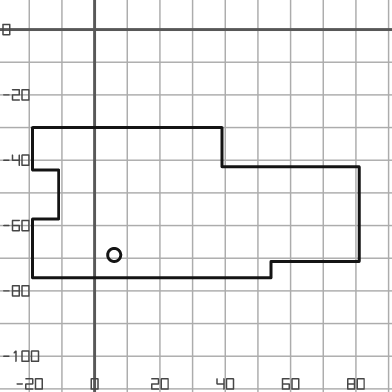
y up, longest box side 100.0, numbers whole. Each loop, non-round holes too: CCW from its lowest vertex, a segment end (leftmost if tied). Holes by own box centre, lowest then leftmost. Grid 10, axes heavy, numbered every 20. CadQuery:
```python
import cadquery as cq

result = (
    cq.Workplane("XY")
    .moveTo(-19.0, -76.0)
    .lineTo(54.0, -76.0)
    .lineTo(54.0, -71.0)
    .lineTo(81.0, -71.0)
    .lineTo(81.0, -42.0)
    .lineTo(39.0, -42.0)
    .lineTo(39.0, -30.0)
    .lineTo(-19.0, -30.0)
    .lineTo(-19.0, -43.0)
    .lineTo(-11.0, -43.0)
    .lineTo(-11.0, -58.0)
    .lineTo(-19.0, -58.0)
    .close()
    .moveTo(6.0, -69.0)
    .circle(2.0)
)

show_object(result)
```